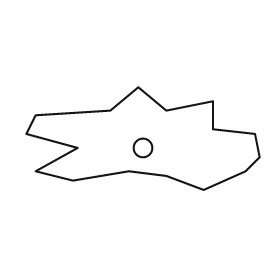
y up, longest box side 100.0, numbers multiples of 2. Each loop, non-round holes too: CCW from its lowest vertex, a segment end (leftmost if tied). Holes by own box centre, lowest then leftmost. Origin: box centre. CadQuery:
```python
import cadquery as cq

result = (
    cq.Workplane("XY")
    .moveTo(26.0, -22.0)
    .lineTo(44.0, -14.0)
    .lineTo(50.0, -8.0)
    .lineTo(48.0, 2.0)
    .lineTo(30.0, 4.0)
    .lineTo(30.0, 16.0)
    .lineTo(10.0, 12.0)
    .lineTo(-2.0, 22.0)
    .lineTo(-14.0, 12.0)
    .lineTo(-46.0, 10.0)
    .lineTo(-50.0, 2.0)
    .lineTo(-28.0, -4.0)
    .lineTo(-46.0, -14.0)
    .lineTo(-30.0, -18.0)
    .lineTo(-6.0, -14.0)
    .lineTo(10.0, -16.0)
    .close()
    .moveTo(0.0, -4.0)
    .circle(4.0)
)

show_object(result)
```